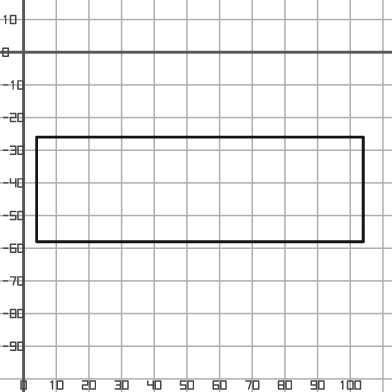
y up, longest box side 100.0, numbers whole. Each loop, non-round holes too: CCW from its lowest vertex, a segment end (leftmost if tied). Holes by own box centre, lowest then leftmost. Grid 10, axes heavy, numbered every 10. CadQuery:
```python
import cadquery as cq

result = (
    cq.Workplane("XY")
    .moveTo(4.0, -58.0)
    .lineTo(104.0, -58.0)
    .lineTo(104.0, -26.0)
    .lineTo(4.0, -26.0)
    .close()
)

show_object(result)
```